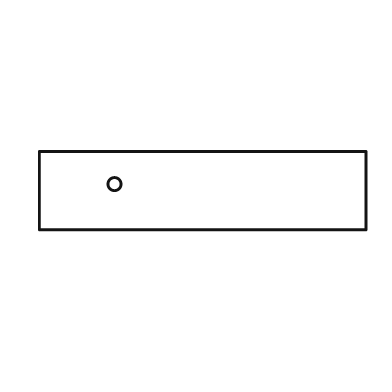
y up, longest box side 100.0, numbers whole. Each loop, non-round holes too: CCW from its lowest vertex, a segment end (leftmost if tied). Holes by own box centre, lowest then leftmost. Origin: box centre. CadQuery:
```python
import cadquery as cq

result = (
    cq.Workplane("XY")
    .moveTo(-50.0, -12.0)
    .lineTo(50.0, -12.0)
    .lineTo(50.0, 12.0)
    .lineTo(-50.0, 12.0)
    .close()
    .moveTo(-27.0, 2.0)
    .circle(2.0)
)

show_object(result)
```